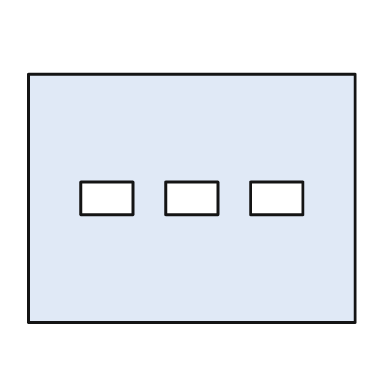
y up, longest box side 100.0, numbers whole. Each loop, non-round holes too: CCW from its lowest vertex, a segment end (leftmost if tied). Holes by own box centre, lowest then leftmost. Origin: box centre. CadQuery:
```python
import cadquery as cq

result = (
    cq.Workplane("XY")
    .moveTo(-50.0, -38.0)
    .lineTo(50.0, -38.0)
    .lineTo(50.0, 38.0)
    .lineTo(-50.0, 38.0)
    .close()
    .moveTo(-34.0, -5.0)
    .lineTo(-18.0, -5.0)
    .lineTo(-18.0, 5.0)
    .lineTo(-34.0, 5.0)
    .close()
    .moveTo(-8.0, -5.0)
    .lineTo(8.0, -5.0)
    .lineTo(8.0, 5.0)
    .lineTo(-8.0, 5.0)
    .close()
    .moveTo(18.0, -5.0)
    .lineTo(34.0, -5.0)
    .lineTo(34.0, 5.0)
    .lineTo(18.0, 5.0)
    .close()
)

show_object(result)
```